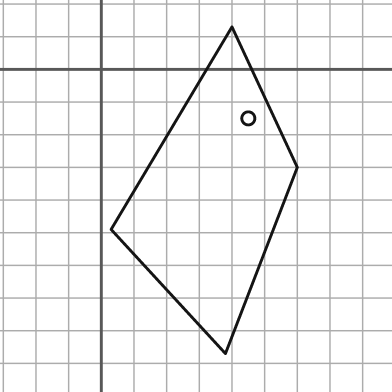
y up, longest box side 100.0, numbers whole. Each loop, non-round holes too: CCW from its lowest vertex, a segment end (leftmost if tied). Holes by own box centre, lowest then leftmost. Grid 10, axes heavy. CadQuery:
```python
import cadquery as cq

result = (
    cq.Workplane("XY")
    .moveTo(38.0, -87.0)
    .lineTo(60.0, -30.0)
    .lineTo(40.0, 13.0)
    .lineTo(3.0, -49.0)
    .close()
    .moveTo(45.0, -15.0)
    .circle(2.0)
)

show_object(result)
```